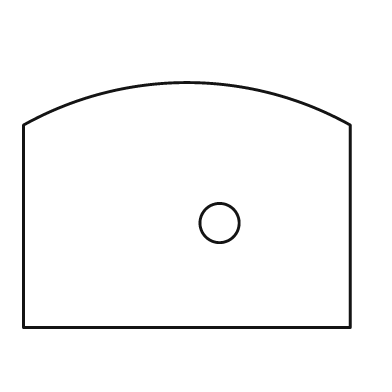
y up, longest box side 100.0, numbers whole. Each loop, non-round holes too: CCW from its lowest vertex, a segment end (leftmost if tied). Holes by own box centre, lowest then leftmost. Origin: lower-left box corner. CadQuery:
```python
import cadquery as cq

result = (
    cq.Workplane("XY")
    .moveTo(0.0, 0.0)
    .lineTo(100.0, 0.0)
    .lineTo(100.0, 62.0)
    .threePointArc((50.0, 75.0), (0.0, 62.0))
    .close()
    .moveTo(60.0, 32.0)
    .circle(6.0)
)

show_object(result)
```